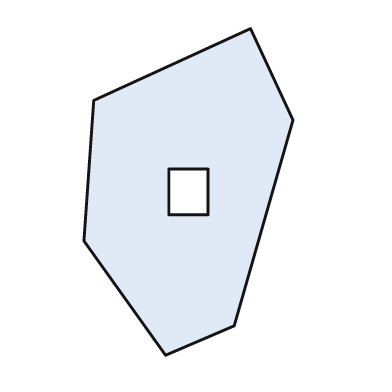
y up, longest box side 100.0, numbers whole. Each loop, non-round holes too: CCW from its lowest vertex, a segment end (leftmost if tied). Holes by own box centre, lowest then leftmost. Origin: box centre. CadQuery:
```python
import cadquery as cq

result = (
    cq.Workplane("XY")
    .moveTo(-7.0, -50.0)
    .lineTo(14.0, -41.0)
    .lineTo(32.0, 22.0)
    .lineTo(19.0, 50.0)
    .lineTo(-29.0, 28.0)
    .lineTo(-32.0, -15.0)
    .close()
    .moveTo(-6.0, -7.0)
    .lineTo(6.0, -7.0)
    .lineTo(6.0, 7.0)
    .lineTo(-6.0, 7.0)
    .close()
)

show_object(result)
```